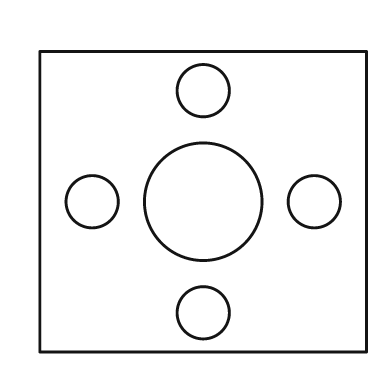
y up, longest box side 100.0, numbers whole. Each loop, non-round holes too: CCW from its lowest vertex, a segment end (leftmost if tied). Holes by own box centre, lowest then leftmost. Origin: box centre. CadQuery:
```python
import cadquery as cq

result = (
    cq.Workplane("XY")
    .moveTo(-50.0, -46.0)
    .lineTo(50.0, -46.0)
    .lineTo(50.0, 46.0)
    .lineTo(-50.0, 46.0)
    .close()
    .moveTo(0.0, -34.0)
    .circle(8.0)
    .moveTo(-34.0, 0.0)
    .circle(8.0)
    .moveTo(0.0, 0.0)
    .circle(18.0)
    .moveTo(34.0, 0.0)
    .circle(8.0)
    .moveTo(0.0, 34.0)
    .circle(8.0)
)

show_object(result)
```